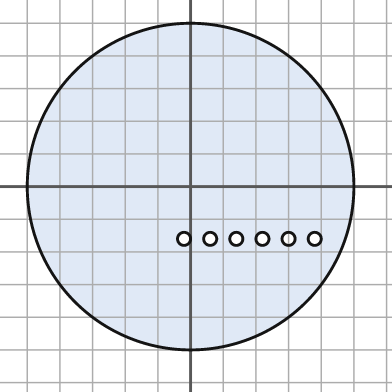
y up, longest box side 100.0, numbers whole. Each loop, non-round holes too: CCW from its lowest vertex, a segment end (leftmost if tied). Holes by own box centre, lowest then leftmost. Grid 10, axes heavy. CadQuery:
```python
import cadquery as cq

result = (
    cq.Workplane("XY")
    .moveTo(0.0, 0.0)
    .circle(50.0)
    .moveTo(-2.0, -16.0)
    .circle(2.0)
    .moveTo(6.0, -16.0)
    .circle(2.0)
    .moveTo(14.0, -16.0)
    .circle(2.0)
    .moveTo(22.0, -16.0)
    .circle(2.0)
    .moveTo(30.0, -16.0)
    .circle(2.0)
    .moveTo(38.0, -16.0)
    .circle(2.0)
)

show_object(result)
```